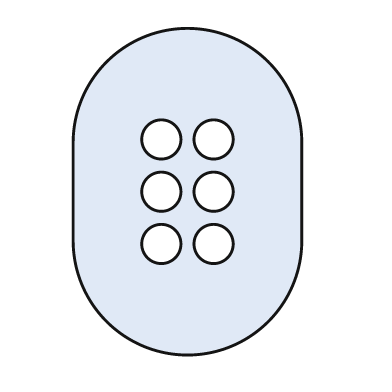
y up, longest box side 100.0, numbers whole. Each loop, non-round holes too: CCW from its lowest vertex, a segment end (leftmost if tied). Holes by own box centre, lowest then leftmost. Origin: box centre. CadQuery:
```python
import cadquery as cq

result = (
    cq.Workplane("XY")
    .moveTo(-35.0, -15.0)
    .threePointArc((0.0, -50.0), (35.0, -15.0))
    .lineTo(35.0, 15.0)
    .threePointArc((0.0, 50.0), (-35.0, 15.0))
    .close()
    .moveTo(-8.0, -16.0)
    .circle(6.0)
    .moveTo(8.0, -16.0)
    .circle(6.0)
    .moveTo(-8.0, 0.0)
    .circle(6.0)
    .moveTo(8.0, 0.0)
    .circle(6.0)
    .moveTo(-8.0, 16.0)
    .circle(6.0)
    .moveTo(8.0, 16.0)
    .circle(6.0)
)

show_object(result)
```